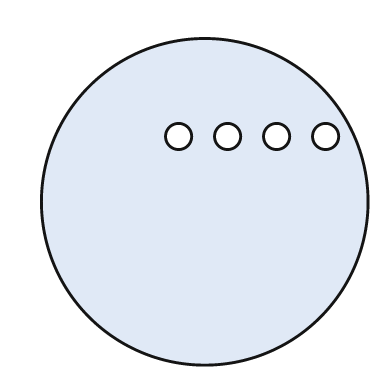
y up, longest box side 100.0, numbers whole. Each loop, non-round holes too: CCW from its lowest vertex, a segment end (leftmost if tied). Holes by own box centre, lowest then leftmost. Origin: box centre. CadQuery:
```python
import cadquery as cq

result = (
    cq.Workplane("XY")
    .moveTo(0.0, 0.0)
    .circle(50.0)
    .moveTo(-8.0, 20.0)
    .circle(4.0)
    .moveTo(7.0, 20.0)
    .circle(4.0)
    .moveTo(22.0, 20.0)
    .circle(4.0)
    .moveTo(37.0, 20.0)
    .circle(4.0)
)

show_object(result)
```